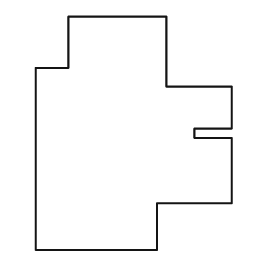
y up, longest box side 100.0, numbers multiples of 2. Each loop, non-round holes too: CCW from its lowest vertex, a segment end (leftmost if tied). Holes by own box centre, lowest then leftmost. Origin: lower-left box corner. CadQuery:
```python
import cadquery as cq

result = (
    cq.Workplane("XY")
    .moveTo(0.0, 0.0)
    .lineTo(52.0, 0.0)
    .lineTo(52.0, 20.0)
    .lineTo(84.0, 20.0)
    .lineTo(84.0, 48.0)
    .lineTo(68.0, 48.0)
    .lineTo(68.0, 52.0)
    .lineTo(84.0, 52.0)
    .lineTo(84.0, 70.0)
    .lineTo(56.0, 70.0)
    .lineTo(56.0, 100.0)
    .lineTo(14.0, 100.0)
    .lineTo(14.0, 78.0)
    .lineTo(0.0, 78.0)
    .close()
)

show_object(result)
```